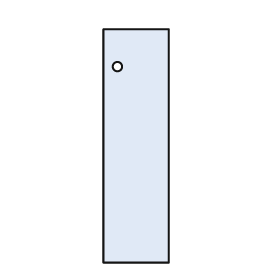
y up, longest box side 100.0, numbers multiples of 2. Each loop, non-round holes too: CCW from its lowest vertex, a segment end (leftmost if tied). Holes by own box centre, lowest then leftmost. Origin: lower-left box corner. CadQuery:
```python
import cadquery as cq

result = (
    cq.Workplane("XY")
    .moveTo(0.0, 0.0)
    .lineTo(28.0, 0.0)
    .lineTo(28.0, 100.0)
    .lineTo(0.0, 100.0)
    .close()
    .moveTo(6.0, 84.0)
    .circle(2.0)
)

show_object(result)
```